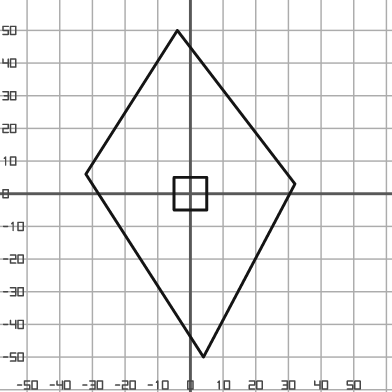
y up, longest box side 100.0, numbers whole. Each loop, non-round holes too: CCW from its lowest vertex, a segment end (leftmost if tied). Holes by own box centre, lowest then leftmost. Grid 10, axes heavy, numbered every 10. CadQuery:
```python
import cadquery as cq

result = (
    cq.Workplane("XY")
    .moveTo(4.0, -50.0)
    .lineTo(32.0, 3.0)
    .lineTo(-4.0, 50.0)
    .lineTo(-32.0, 6.0)
    .close()
    .moveTo(-5.0, -5.0)
    .lineTo(5.0, -5.0)
    .lineTo(5.0, 5.0)
    .lineTo(-5.0, 5.0)
    .close()
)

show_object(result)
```